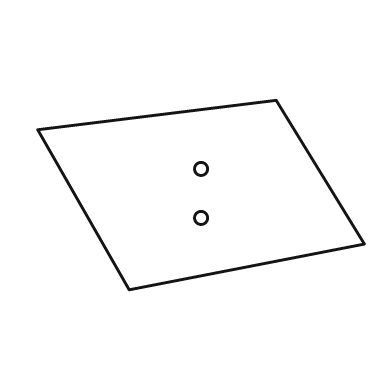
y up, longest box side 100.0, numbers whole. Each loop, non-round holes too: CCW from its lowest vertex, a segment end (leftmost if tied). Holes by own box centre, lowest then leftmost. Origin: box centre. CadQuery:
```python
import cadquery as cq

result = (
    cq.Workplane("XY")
    .moveTo(-22.0, -29.0)
    .lineTo(50.0, -15.0)
    .lineTo(23.0, 29.0)
    .lineTo(-50.0, 20.0)
    .close()
    .moveTo(0.0, -7.0)
    .circle(2.0)
    .moveTo(0.0, 8.0)
    .circle(2.0)
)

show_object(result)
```